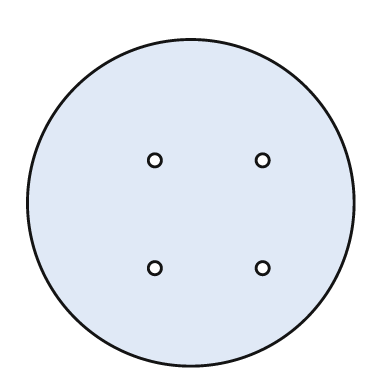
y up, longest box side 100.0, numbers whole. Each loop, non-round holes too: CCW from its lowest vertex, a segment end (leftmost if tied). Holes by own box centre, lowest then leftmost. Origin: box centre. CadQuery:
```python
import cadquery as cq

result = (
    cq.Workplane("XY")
    .moveTo(0.0, 0.0)
    .circle(50.0)
    .moveTo(-11.0, -20.0)
    .circle(2.0)
    .moveTo(22.0, -20.0)
    .circle(2.0)
    .moveTo(-11.0, 13.0)
    .circle(2.0)
    .moveTo(22.0, 13.0)
    .circle(2.0)
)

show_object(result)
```